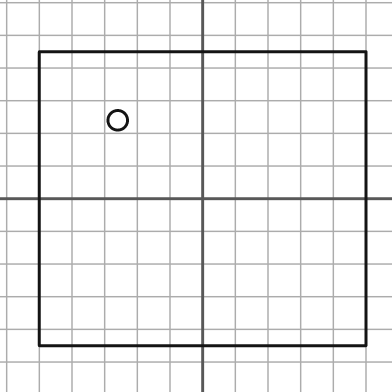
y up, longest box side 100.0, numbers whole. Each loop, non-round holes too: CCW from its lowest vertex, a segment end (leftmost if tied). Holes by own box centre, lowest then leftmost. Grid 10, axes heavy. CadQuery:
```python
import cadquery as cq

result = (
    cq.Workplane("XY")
    .moveTo(-50.0, -45.0)
    .lineTo(50.0, -45.0)
    .lineTo(50.0, 45.0)
    .lineTo(-50.0, 45.0)
    .close()
    .moveTo(-26.0, 24.0)
    .circle(3.0)
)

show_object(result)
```